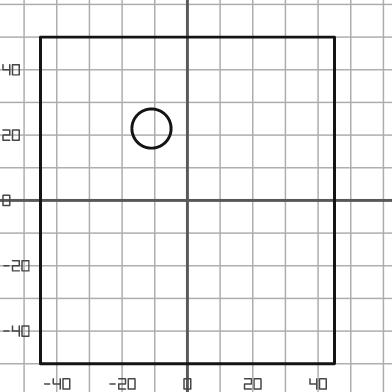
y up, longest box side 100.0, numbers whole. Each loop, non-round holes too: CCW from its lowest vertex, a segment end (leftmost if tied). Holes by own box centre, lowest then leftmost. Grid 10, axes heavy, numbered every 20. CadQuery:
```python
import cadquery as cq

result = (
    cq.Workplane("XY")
    .moveTo(-45.0, -50.0)
    .lineTo(45.0, -50.0)
    .lineTo(45.0, 50.0)
    .lineTo(-45.0, 50.0)
    .close()
    .moveTo(-11.0, 22.0)
    .circle(6.0)
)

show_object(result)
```